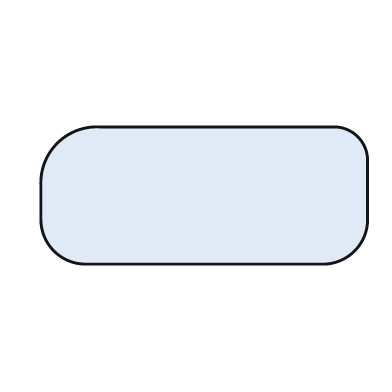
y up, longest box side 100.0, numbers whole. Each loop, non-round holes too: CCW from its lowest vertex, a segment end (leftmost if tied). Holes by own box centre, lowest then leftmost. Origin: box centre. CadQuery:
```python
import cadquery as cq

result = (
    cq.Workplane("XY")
    .moveTo(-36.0, -21.0)
    .lineTo(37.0, -21.0)
    .threePointArc((46.0, -17.0), (50.0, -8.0))
    .lineTo(50.0, 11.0)
    .threePointArc((47.0, 18.0), (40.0, 21.0))
    .lineTo(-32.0, 21.0)
    .threePointArc((-45.0, 16.0), (-50.0, 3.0))
    .lineTo(-50.0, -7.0)
    .threePointArc((-46.0, -17.0), (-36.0, -21.0))
    .close()
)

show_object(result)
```